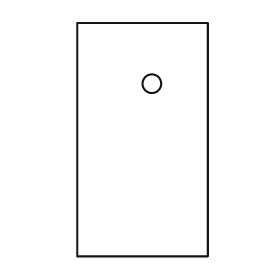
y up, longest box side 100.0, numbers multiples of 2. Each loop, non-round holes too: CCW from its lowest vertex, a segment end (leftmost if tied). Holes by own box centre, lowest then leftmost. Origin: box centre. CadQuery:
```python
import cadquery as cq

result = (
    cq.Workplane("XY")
    .moveTo(-28.0, -50.0)
    .lineTo(28.0, -50.0)
    .lineTo(28.0, 50.0)
    .lineTo(-28.0, 50.0)
    .close()
    .moveTo(4.0, 24.0)
    .circle(4.0)
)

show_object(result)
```